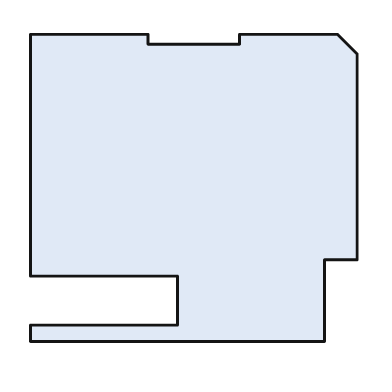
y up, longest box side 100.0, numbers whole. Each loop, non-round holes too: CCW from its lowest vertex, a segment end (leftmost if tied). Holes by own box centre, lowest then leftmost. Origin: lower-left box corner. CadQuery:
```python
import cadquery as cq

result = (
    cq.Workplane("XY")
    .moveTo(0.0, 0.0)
    .lineTo(90.0, 0.0)
    .lineTo(90.0, 25.0)
    .lineTo(100.0, 25.0)
    .lineTo(100.0, 88.0)
    .lineTo(94.0, 94.0)
    .lineTo(64.0, 94.0)
    .lineTo(64.0, 91.0)
    .lineTo(36.0, 91.0)
    .lineTo(36.0, 94.0)
    .lineTo(0.0, 94.0)
    .lineTo(0.0, 20.0)
    .lineTo(45.0, 20.0)
    .lineTo(45.0, 5.0)
    .lineTo(0.0, 5.0)
    .close()
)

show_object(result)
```